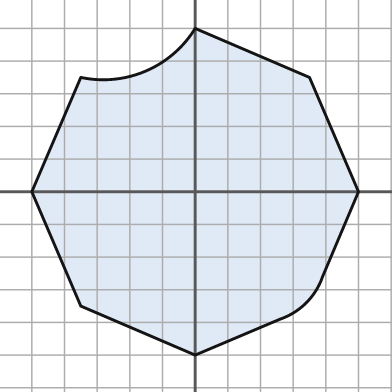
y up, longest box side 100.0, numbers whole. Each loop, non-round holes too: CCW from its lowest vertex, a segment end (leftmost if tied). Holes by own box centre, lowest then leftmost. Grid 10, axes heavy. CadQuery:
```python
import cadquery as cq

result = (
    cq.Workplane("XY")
    .moveTo(0.0, -50.0)
    .lineTo(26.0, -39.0)
    .threePointArc((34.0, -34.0), (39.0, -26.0))
    .lineTo(50.0, 0.0)
    .lineTo(35.0, 35.0)
    .lineTo(0.0, 50.0)
    .threePointArc((-15.0, 37.0), (-35.0, 35.0))
    .lineTo(-50.0, 0.0)
    .lineTo(-35.0, -35.0)
    .close()
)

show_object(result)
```